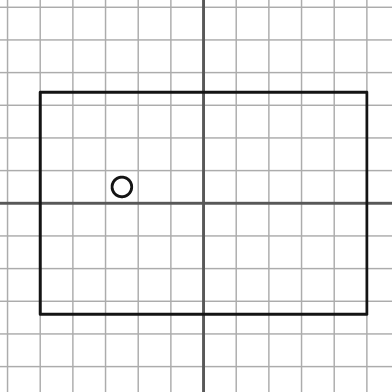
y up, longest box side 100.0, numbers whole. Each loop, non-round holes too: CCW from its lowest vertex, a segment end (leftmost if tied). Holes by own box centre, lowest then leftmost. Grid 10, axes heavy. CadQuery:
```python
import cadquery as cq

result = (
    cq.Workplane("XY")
    .moveTo(-50.0, -34.0)
    .lineTo(50.0, -34.0)
    .lineTo(50.0, 34.0)
    .lineTo(-50.0, 34.0)
    .close()
    .moveTo(-25.0, 5.0)
    .circle(3.0)
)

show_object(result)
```